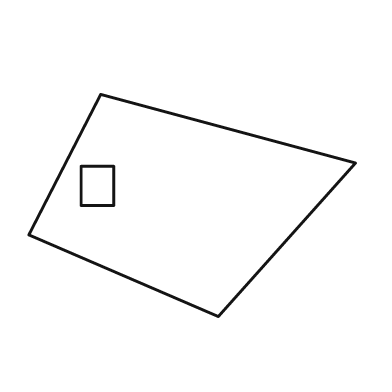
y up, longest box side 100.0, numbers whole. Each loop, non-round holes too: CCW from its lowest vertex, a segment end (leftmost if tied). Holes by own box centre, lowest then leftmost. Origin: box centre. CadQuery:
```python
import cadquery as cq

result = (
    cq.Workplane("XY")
    .moveTo(8.0, -34.0)
    .lineTo(50.0, 13.0)
    .lineTo(-28.0, 34.0)
    .lineTo(-50.0, -9.0)
    .close()
    .moveTo(-34.0, 0.0)
    .lineTo(-24.0, 0.0)
    .lineTo(-24.0, 12.0)
    .lineTo(-34.0, 12.0)
    .close()
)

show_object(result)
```